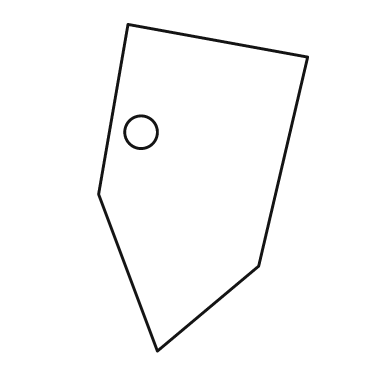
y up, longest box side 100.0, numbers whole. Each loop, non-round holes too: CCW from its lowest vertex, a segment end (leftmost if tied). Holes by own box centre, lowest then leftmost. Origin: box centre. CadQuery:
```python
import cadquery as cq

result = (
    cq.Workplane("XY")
    .moveTo(-14.0, -50.0)
    .lineTo(17.0, -24.0)
    .lineTo(32.0, 40.0)
    .lineTo(-23.0, 50.0)
    .lineTo(-32.0, -2.0)
    .close()
    .moveTo(-19.0, 17.0)
    .circle(5.0)
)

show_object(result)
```